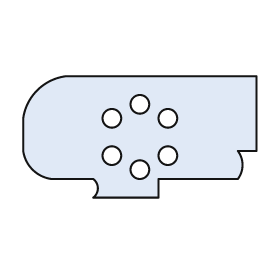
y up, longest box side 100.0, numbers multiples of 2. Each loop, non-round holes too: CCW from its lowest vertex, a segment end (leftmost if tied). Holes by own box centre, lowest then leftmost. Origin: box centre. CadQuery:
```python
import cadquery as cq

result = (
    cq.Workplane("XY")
    .moveTo(-20.0, -26.0)
    .lineTo(8.0, -26.0)
    .lineTo(8.0, -18.0)
    .lineTo(42.0, -18.0)
    .threePointArc((44.0, -12.0), (42.0, -6.0))
    .lineTo(50.0, -6.0)
    .lineTo(50.0, 26.0)
    .lineTo(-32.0, 26.0)
    .threePointArc((-44.0, 20.0), (-50.0, 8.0))
    .lineTo(-50.0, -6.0)
    .threePointArc((-46.0, -14.0), (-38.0, -18.0))
    .lineTo(-20.0, -18.0)
    .threePointArc((-18.0, -22.0), (-20.0, -26.0))
    .close()
    .moveTo(0.0, -14.0)
    .circle(4.0)
    .moveTo(-12.0, -8.0)
    .circle(4.0)
    .moveTo(12.0, -8.0)
    .circle(4.0)
    .moveTo(-12.0, 8.0)
    .circle(4.0)
    .moveTo(12.0, 8.0)
    .circle(4.0)
    .moveTo(0.0, 14.0)
    .circle(4.0)
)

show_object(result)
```